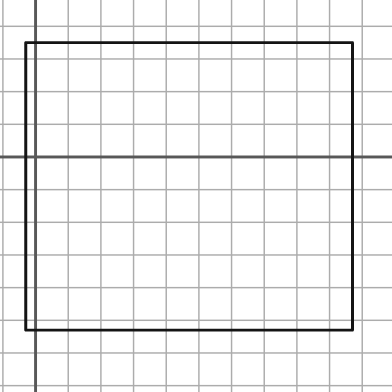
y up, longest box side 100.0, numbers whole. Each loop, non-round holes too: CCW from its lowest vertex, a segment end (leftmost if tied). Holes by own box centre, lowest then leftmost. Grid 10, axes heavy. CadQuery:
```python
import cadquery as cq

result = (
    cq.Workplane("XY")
    .moveTo(-3.0, -53.0)
    .lineTo(97.0, -53.0)
    .lineTo(97.0, 35.0)
    .lineTo(-3.0, 35.0)
    .close()
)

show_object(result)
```